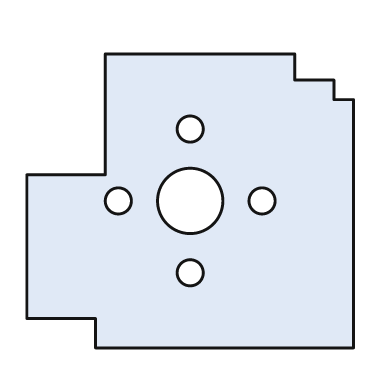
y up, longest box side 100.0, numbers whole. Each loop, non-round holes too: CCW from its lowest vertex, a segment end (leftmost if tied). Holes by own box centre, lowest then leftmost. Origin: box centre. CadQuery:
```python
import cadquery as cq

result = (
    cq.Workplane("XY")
    .moveTo(-29.0, -45.0)
    .lineTo(50.0, -45.0)
    .lineTo(50.0, 31.0)
    .lineTo(44.0, 31.0)
    .lineTo(44.0, 37.0)
    .lineTo(32.0, 37.0)
    .lineTo(32.0, 45.0)
    .lineTo(-26.0, 45.0)
    .lineTo(-26.0, 8.0)
    .lineTo(-50.0, 8.0)
    .lineTo(-50.0, -36.0)
    .lineTo(-29.0, -36.0)
    .close()
    .moveTo(0.0, -22.0)
    .circle(4.0)
    .moveTo(-22.0, 0.0)
    .circle(4.0)
    .moveTo(0.0, 0.0)
    .circle(10.0)
    .moveTo(22.0, 0.0)
    .circle(4.0)
    .moveTo(0.0, 22.0)
    .circle(4.0)
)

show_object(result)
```